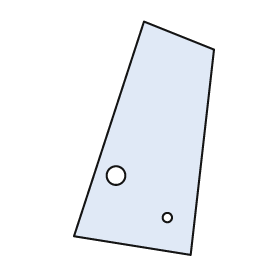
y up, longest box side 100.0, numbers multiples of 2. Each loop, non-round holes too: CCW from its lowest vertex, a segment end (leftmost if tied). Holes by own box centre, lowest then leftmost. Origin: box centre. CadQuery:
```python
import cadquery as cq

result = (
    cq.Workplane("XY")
    .moveTo(20.0, -50.0)
    .lineTo(30.0, 38.0)
    .lineTo(0.0, 50.0)
    .lineTo(-30.0, -42.0)
    .close()
    .moveTo(10.0, -34.0)
    .circle(2.0)
    .moveTo(-12.0, -16.0)
    .circle(4.0)
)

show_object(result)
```